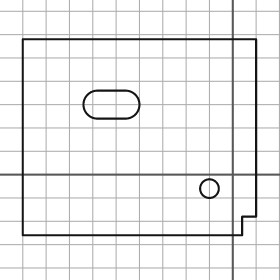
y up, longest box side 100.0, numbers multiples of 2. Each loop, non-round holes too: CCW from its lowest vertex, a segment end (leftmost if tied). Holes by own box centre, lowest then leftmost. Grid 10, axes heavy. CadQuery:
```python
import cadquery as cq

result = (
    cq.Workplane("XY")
    .moveTo(-90.0, -26.0)
    .lineTo(4.0, -26.0)
    .lineTo(4.0, -18.0)
    .lineTo(10.0, -18.0)
    .lineTo(10.0, 58.0)
    .lineTo(-90.0, 58.0)
    .close()
    .moveTo(-10.0, -6.0)
    .circle(4.0)
    .moveTo(-58.0, 24.0)
    .lineTo(-46.0, 24.0)
    .threePointArc((-40.0, 30.0), (-46.0, 36.0))
    .lineTo(-58.0, 36.0)
    .threePointArc((-64.0, 30.0), (-58.0, 24.0))
    .close()
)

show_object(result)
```